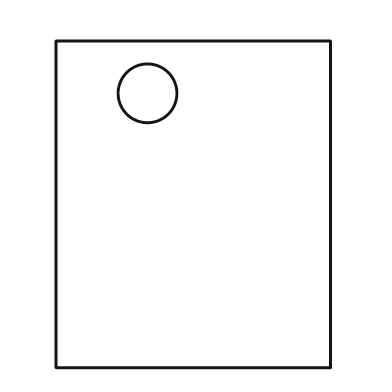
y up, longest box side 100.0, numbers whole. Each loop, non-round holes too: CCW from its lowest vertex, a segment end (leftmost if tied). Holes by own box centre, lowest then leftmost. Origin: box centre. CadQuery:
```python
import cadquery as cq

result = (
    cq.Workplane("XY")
    .moveTo(-42.0, -50.0)
    .lineTo(42.0, -50.0)
    .lineTo(42.0, 50.0)
    .lineTo(-42.0, 50.0)
    .close()
    .moveTo(-14.0, 34.0)
    .circle(9.0)
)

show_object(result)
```